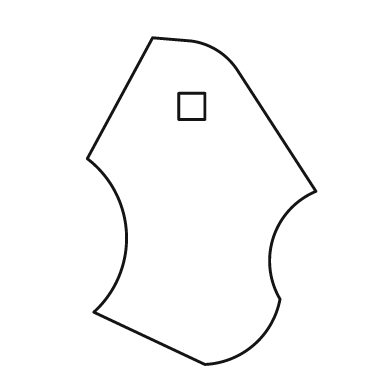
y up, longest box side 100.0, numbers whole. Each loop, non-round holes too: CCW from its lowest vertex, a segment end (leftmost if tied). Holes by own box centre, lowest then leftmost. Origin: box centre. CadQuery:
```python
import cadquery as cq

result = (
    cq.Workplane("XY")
    .moveTo(1.0, -50.0)
    .threePointArc((16.0, -44.0), (24.0, -30.0))
    .threePointArc((22.0, -11.0), (35.0, 3.0))
    .lineTo(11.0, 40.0)
    .threePointArc((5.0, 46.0), (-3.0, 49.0))
    .lineTo(-15.0, 50.0)
    .lineTo(-35.0, 13.0)
    .threePointArc((-23.0, -10.0), (-33.0, -34.0))
    .close()
    .moveTo(-7.0, 25.0)
    .lineTo(1.0, 25.0)
    .lineTo(1.0, 33.0)
    .lineTo(-7.0, 33.0)
    .close()
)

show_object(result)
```